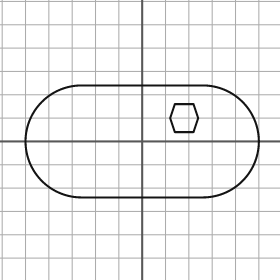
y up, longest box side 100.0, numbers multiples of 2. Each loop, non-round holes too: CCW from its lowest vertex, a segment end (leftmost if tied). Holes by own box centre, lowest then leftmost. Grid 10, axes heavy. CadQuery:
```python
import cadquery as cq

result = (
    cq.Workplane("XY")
    .moveTo(-26.0, -24.0)
    .lineTo(26.0, -24.0)
    .threePointArc((50.0, 0.0), (26.0, 24.0))
    .lineTo(-26.0, 24.0)
    .threePointArc((-50.0, 0.0), (-26.0, -24.0))
    .close()
    .moveTo(14.0, 4.0)
    .lineTo(22.0, 4.0)
    .lineTo(24.0, 10.0)
    .lineTo(22.0, 16.0)
    .lineTo(14.0, 16.0)
    .lineTo(12.0, 10.0)
    .close()
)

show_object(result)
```